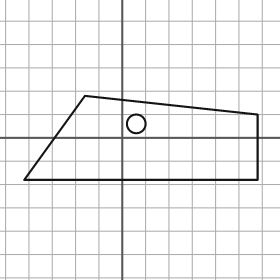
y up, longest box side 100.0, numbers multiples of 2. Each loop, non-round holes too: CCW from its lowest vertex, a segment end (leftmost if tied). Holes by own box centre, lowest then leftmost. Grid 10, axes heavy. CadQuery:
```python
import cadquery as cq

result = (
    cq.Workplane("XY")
    .moveTo(-42.0, -18.0)
    .lineTo(58.0, -18.0)
    .lineTo(58.0, 10.0)
    .lineTo(-16.0, 18.0)
    .close()
    .moveTo(6.0, 6.0)
    .circle(4.0)
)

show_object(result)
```